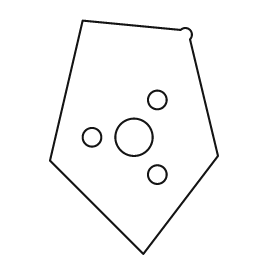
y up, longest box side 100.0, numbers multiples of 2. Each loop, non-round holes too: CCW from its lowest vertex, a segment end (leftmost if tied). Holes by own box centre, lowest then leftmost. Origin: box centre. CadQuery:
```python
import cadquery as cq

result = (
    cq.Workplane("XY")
    .moveTo(4.0, -50.0)
    .lineTo(36.0, -8.0)
    .lineTo(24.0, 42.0)
    .threePointArc((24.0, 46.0), (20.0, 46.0))
    .lineTo(-22.0, 50.0)
    .lineTo(-36.0, -10.0)
    .close()
    .moveTo(10.0, -16.0)
    .circle(4.0)
    .moveTo(-18.0, 0.0)
    .circle(4.0)
    .moveTo(0.0, 0.0)
    .circle(8.0)
    .moveTo(10.0, 16.0)
    .circle(4.0)
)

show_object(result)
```